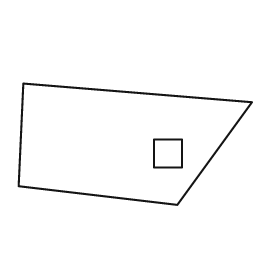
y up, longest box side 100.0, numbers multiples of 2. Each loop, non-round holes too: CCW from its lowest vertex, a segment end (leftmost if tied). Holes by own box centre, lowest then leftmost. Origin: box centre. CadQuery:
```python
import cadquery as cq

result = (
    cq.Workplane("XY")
    .moveTo(18.0, -26.0)
    .lineTo(50.0, 18.0)
    .lineTo(-48.0, 26.0)
    .lineTo(-50.0, -18.0)
    .close()
    .moveTo(8.0, -10.0)
    .lineTo(20.0, -10.0)
    .lineTo(20.0, 2.0)
    .lineTo(8.0, 2.0)
    .close()
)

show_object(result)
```